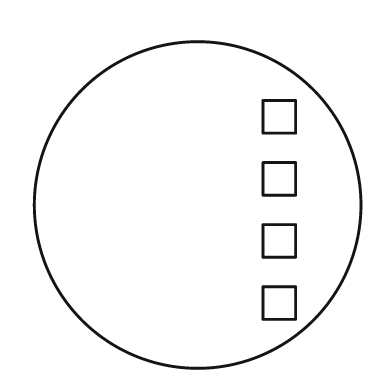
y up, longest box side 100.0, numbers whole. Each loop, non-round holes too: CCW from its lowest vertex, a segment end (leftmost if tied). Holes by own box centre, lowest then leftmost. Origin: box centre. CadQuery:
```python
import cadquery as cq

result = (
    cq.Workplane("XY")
    .moveTo(0.0, 0.0)
    .circle(50.0)
    .moveTo(20.0, -35.0)
    .lineTo(30.0, -35.0)
    .lineTo(30.0, -25.0)
    .lineTo(20.0, -25.0)
    .close()
    .moveTo(20.0, -16.0)
    .lineTo(30.0, -16.0)
    .lineTo(30.0, -6.0)
    .lineTo(20.0, -6.0)
    .close()
    .moveTo(20.0, 3.0)
    .lineTo(30.0, 3.0)
    .lineTo(30.0, 13.0)
    .lineTo(20.0, 13.0)
    .close()
    .moveTo(20.0, 22.0)
    .lineTo(30.0, 22.0)
    .lineTo(30.0, 32.0)
    .lineTo(20.0, 32.0)
    .close()
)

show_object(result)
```